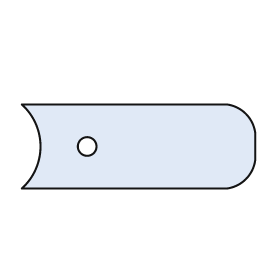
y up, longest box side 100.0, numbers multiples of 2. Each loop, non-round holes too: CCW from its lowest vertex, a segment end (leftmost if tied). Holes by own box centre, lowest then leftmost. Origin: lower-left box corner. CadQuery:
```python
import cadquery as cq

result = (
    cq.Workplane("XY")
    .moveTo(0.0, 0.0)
    .lineTo(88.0, 0.0)
    .threePointArc((96.0, 4.0), (100.0, 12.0))
    .lineTo(100.0, 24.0)
    .threePointArc((96.0, 32.0), (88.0, 36.0))
    .lineTo(0.0, 36.0)
    .threePointArc((8.0, 18.0), (0.0, 0.0))
    .close()
    .moveTo(28.0, 18.0)
    .circle(4.0)
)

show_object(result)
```